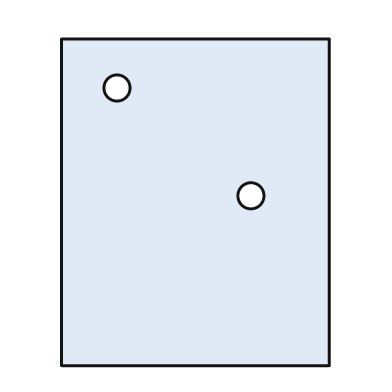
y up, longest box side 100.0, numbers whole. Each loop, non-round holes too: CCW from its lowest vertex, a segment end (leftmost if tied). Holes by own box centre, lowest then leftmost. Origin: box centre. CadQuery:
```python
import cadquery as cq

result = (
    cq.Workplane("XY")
    .moveTo(-41.0, -50.0)
    .lineTo(41.0, -50.0)
    .lineTo(41.0, 50.0)
    .lineTo(-41.0, 50.0)
    .close()
    .moveTo(17.0, 2.0)
    .circle(4.0)
    .moveTo(-24.0, 35.0)
    .circle(4.0)
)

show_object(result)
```